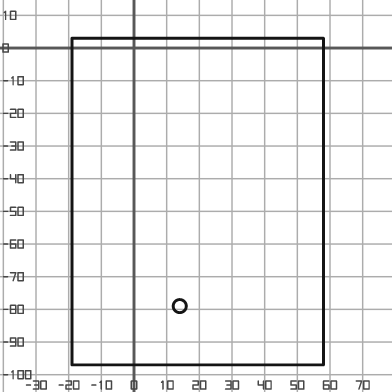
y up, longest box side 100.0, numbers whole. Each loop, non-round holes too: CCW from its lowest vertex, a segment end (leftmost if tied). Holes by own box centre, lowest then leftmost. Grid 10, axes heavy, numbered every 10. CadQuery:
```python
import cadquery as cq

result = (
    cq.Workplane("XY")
    .moveTo(-19.0, -97.0)
    .lineTo(58.0, -97.0)
    .lineTo(58.0, 3.0)
    .lineTo(-19.0, 3.0)
    .close()
    .moveTo(14.0, -79.0)
    .circle(2.0)
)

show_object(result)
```